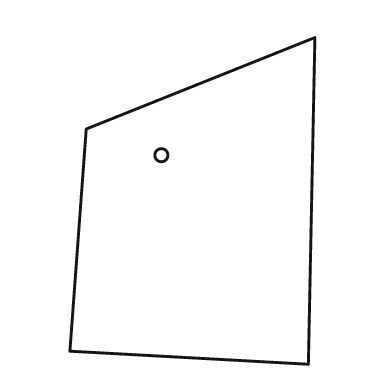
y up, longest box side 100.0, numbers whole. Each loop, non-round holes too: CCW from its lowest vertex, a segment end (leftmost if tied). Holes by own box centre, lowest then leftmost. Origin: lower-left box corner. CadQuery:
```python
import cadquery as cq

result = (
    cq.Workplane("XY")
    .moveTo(73.0, 0.0)
    .lineTo(75.0, 100.0)
    .lineTo(5.0, 72.0)
    .lineTo(0.0, 4.0)
    .close()
    .moveTo(28.0, 64.0)
    .circle(2.0)
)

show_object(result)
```